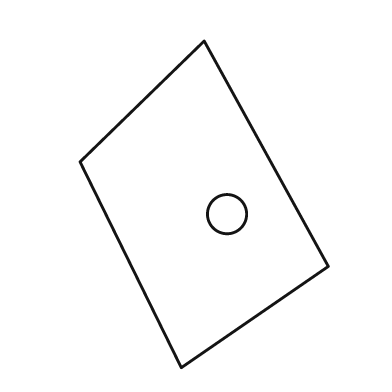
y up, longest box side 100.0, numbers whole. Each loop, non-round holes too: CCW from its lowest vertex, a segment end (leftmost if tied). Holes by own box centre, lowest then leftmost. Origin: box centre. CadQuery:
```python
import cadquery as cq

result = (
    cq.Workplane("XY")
    .moveTo(-7.0, -50.0)
    .lineTo(38.0, -19.0)
    .lineTo(0.0, 50.0)
    .lineTo(-38.0, 13.0)
    .close()
    .moveTo(7.0, -3.0)
    .circle(6.0)
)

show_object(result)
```